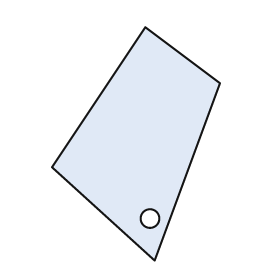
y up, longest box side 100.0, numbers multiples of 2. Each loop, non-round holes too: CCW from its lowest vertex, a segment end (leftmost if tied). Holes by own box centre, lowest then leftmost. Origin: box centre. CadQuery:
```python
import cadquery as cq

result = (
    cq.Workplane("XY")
    .moveTo(8.0, -50.0)
    .lineTo(36.0, 26.0)
    .lineTo(4.0, 50.0)
    .lineTo(-36.0, -10.0)
    .close()
    .moveTo(6.0, -32.0)
    .circle(4.0)
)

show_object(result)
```